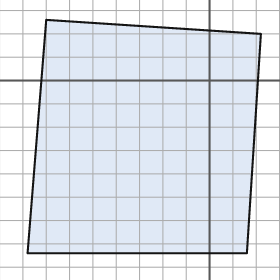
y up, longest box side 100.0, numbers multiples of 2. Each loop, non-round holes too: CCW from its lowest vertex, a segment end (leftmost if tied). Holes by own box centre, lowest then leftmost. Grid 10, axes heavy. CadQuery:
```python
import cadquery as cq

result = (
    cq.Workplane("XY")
    .moveTo(-78.0, -74.0)
    .lineTo(16.0, -74.0)
    .lineTo(22.0, 20.0)
    .lineTo(-70.0, 26.0)
    .close()
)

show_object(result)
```